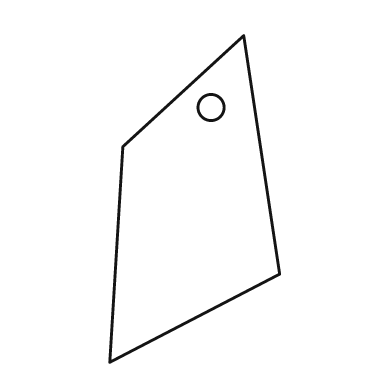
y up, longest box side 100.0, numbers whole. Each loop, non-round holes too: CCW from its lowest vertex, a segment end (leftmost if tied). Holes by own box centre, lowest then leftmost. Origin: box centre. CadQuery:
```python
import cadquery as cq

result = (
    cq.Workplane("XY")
    .moveTo(-26.0, -50.0)
    .lineTo(26.0, -23.0)
    .lineTo(15.0, 50.0)
    .lineTo(-22.0, 16.0)
    .close()
    .moveTo(5.0, 28.0)
    .circle(4.0)
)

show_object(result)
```